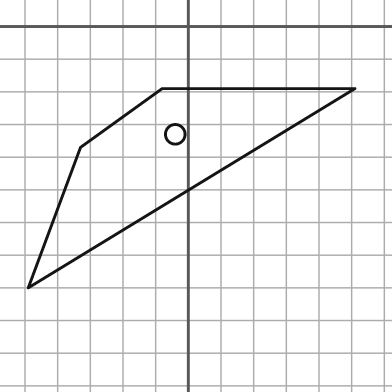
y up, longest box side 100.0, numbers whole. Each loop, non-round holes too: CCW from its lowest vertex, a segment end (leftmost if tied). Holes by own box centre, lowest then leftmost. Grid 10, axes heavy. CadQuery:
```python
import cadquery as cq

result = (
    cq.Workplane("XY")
    .moveTo(-49.0, -80.0)
    .lineTo(51.0, -19.0)
    .lineTo(-8.0, -19.0)
    .lineTo(-33.0, -37.0)
    .close()
    .moveTo(-4.0, -33.0)
    .circle(3.0)
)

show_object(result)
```